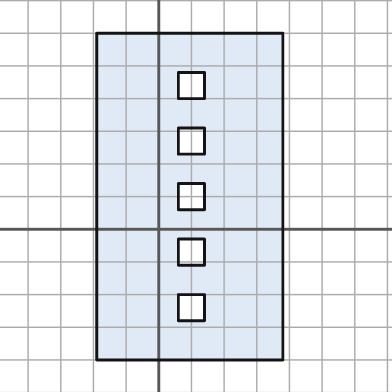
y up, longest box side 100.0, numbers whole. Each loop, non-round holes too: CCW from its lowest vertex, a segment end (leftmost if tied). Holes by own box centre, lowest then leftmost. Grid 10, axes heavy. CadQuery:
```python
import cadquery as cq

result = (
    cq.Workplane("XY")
    .moveTo(-19.0, -40.0)
    .lineTo(38.0, -40.0)
    .lineTo(38.0, 60.0)
    .lineTo(-19.0, 60.0)
    .close()
    .moveTo(6.0, -28.0)
    .lineTo(14.0, -28.0)
    .lineTo(14.0, -20.0)
    .lineTo(6.0, -20.0)
    .close()
    .moveTo(6.0, -11.0)
    .lineTo(14.0, -11.0)
    .lineTo(14.0, -3.0)
    .lineTo(6.0, -3.0)
    .close()
    .moveTo(6.0, 6.0)
    .lineTo(14.0, 6.0)
    .lineTo(14.0, 14.0)
    .lineTo(6.0, 14.0)
    .close()
    .moveTo(6.0, 23.0)
    .lineTo(14.0, 23.0)
    .lineTo(14.0, 31.0)
    .lineTo(6.0, 31.0)
    .close()
    .moveTo(6.0, 40.0)
    .lineTo(14.0, 40.0)
    .lineTo(14.0, 48.0)
    .lineTo(6.0, 48.0)
    .close()
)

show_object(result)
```